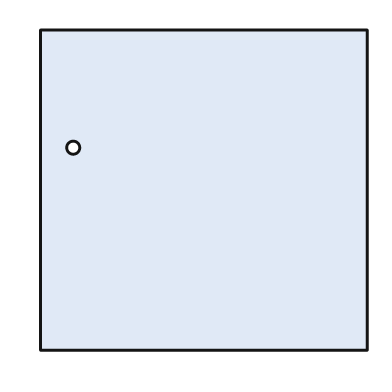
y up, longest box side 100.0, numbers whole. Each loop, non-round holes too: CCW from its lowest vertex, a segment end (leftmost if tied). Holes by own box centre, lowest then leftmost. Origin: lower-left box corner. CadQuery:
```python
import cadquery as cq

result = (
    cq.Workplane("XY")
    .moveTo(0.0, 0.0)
    .lineTo(100.0, 0.0)
    .lineTo(100.0, 98.0)
    .lineTo(0.0, 98.0)
    .close()
    .moveTo(10.0, 62.0)
    .circle(2.0)
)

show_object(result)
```